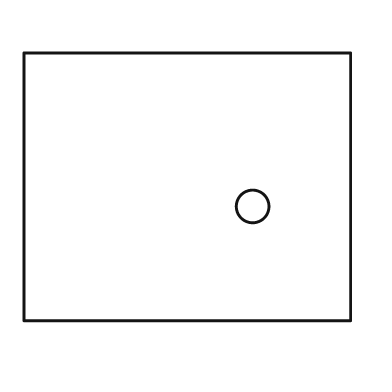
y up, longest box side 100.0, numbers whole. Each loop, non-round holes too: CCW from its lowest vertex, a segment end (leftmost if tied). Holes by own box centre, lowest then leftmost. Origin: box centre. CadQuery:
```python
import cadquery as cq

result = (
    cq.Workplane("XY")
    .moveTo(-50.0, -41.0)
    .lineTo(50.0, -41.0)
    .lineTo(50.0, 41.0)
    .lineTo(-50.0, 41.0)
    .close()
    .moveTo(20.0, -6.0)
    .circle(5.0)
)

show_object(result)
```